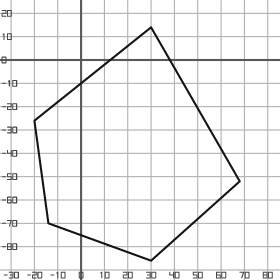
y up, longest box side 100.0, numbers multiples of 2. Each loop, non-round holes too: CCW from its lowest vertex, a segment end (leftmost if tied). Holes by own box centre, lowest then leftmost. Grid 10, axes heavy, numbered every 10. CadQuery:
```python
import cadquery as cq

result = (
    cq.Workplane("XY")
    .moveTo(30.0, -86.0)
    .lineTo(68.0, -52.0)
    .lineTo(30.0, 14.0)
    .lineTo(-20.0, -26.0)
    .lineTo(-14.0, -70.0)
    .close()
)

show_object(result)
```